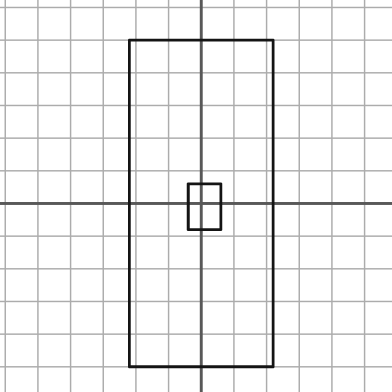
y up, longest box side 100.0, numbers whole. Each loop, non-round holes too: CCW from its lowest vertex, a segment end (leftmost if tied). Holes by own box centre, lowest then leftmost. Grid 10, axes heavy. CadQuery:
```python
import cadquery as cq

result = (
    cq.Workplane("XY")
    .moveTo(-22.0, -50.0)
    .lineTo(22.0, -50.0)
    .lineTo(22.0, 50.0)
    .lineTo(-22.0, 50.0)
    .close()
    .moveTo(-4.0, -8.0)
    .lineTo(6.0, -8.0)
    .lineTo(6.0, 6.0)
    .lineTo(-4.0, 6.0)
    .close()
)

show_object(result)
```